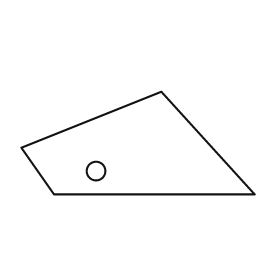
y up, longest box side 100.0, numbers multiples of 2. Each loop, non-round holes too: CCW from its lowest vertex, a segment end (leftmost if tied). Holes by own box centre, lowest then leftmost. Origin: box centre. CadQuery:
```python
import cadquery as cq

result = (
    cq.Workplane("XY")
    .moveTo(-36.0, -22.0)
    .lineTo(50.0, -22.0)
    .lineTo(10.0, 22.0)
    .lineTo(-50.0, -2.0)
    .close()
    .moveTo(-18.0, -12.0)
    .circle(4.0)
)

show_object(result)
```